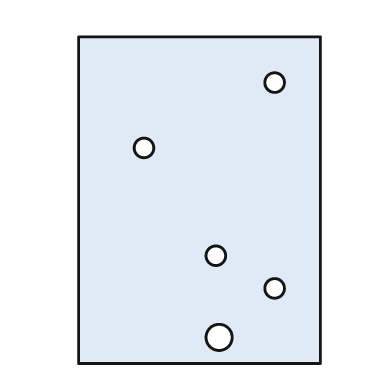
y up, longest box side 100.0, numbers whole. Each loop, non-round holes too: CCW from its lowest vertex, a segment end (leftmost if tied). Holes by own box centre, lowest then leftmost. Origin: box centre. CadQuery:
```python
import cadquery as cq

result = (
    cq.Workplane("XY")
    .moveTo(-37.0, -50.0)
    .lineTo(37.0, -50.0)
    .lineTo(37.0, 50.0)
    .lineTo(-37.0, 50.0)
    .close()
    .moveTo(6.0, -42.0)
    .circle(4.0)
    .moveTo(23.0, -27.0)
    .circle(3.0)
    .moveTo(5.0, -17.0)
    .circle(3.0)
    .moveTo(-17.0, 16.0)
    .circle(3.0)
    .moveTo(23.0, 36.0)
    .circle(3.0)
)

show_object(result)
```